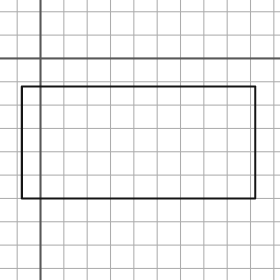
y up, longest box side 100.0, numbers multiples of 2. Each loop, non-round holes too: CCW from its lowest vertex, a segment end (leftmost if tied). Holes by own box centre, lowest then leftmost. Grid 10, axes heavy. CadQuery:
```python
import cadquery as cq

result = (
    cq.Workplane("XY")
    .moveTo(-8.0, -60.0)
    .lineTo(92.0, -60.0)
    .lineTo(92.0, -12.0)
    .lineTo(-8.0, -12.0)
    .close()
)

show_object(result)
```